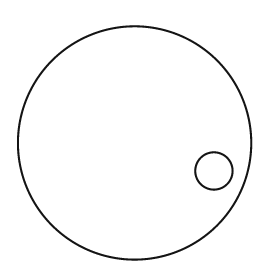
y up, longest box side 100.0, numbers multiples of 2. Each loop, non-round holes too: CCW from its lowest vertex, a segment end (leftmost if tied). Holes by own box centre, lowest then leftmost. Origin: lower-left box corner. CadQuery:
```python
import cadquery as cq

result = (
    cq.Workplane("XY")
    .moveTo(50.0, 50.0)
    .circle(50.0)
    .moveTo(84.0, 38.0)
    .circle(8.0)
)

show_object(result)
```